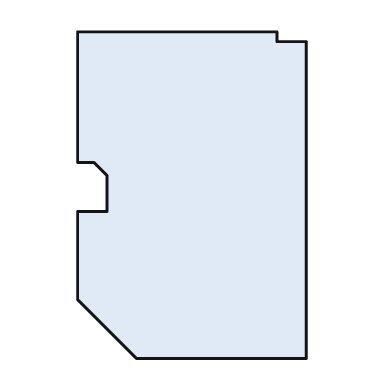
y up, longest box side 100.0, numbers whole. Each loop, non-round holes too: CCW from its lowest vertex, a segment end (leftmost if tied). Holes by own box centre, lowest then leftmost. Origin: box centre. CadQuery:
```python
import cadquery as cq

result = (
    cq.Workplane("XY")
    .moveTo(-17.0, -50.0)
    .lineTo(35.0, -50.0)
    .lineTo(35.0, 47.0)
    .lineTo(26.0, 47.0)
    .lineTo(26.0, 50.0)
    .lineTo(-35.0, 50.0)
    .lineTo(-35.0, 10.0)
    .lineTo(-30.0, 10.0)
    .lineTo(-26.0, 6.0)
    .lineTo(-26.0, -5.0)
    .lineTo(-35.0, -5.0)
    .lineTo(-35.0, -32.0)
    .close()
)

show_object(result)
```